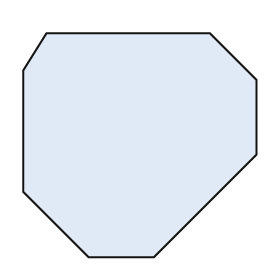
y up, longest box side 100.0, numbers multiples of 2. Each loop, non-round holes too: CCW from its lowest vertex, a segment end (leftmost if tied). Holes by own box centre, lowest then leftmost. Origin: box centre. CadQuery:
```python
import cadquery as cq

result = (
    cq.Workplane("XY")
    .moveTo(-22.0, -48.0)
    .lineTo(6.0, -48.0)
    .lineTo(50.0, -4.0)
    .lineTo(50.0, 28.0)
    .lineTo(30.0, 48.0)
    .lineTo(-40.0, 48.0)
    .lineTo(-50.0, 32.0)
    .lineTo(-50.0, -20.0)
    .close()
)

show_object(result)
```